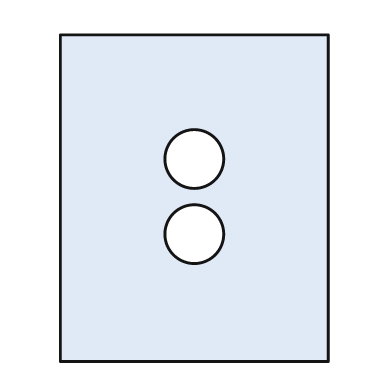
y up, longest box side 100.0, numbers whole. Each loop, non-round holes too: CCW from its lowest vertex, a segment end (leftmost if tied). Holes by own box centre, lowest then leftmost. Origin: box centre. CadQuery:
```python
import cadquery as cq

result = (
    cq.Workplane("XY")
    .moveTo(-41.0, -50.0)
    .lineTo(41.0, -50.0)
    .lineTo(41.0, 50.0)
    .lineTo(-41.0, 50.0)
    .close()
    .moveTo(0.0, -11.0)
    .circle(9.0)
    .moveTo(0.0, 12.0)
    .circle(9.0)
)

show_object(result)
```